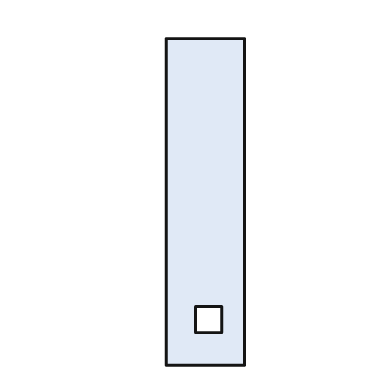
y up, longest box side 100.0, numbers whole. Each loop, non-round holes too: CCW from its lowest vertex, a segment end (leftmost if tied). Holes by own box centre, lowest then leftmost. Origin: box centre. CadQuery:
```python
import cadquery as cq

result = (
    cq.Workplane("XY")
    .moveTo(-12.0, -50.0)
    .lineTo(12.0, -50.0)
    .lineTo(12.0, 50.0)
    .lineTo(-12.0, 50.0)
    .close()
    .moveTo(-3.0, -40.0)
    .lineTo(5.0, -40.0)
    .lineTo(5.0, -32.0)
    .lineTo(-3.0, -32.0)
    .close()
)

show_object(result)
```